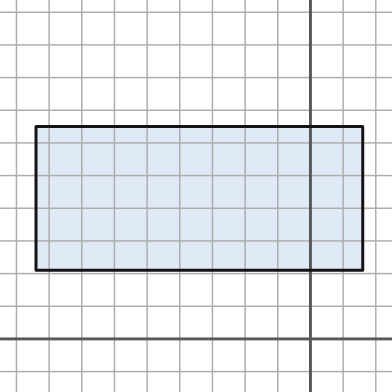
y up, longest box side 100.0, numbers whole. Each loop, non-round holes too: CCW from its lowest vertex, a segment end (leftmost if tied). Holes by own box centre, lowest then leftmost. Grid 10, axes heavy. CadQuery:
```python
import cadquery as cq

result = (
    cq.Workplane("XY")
    .moveTo(-84.0, 21.0)
    .lineTo(16.0, 21.0)
    .lineTo(16.0, 65.0)
    .lineTo(-84.0, 65.0)
    .close()
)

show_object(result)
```